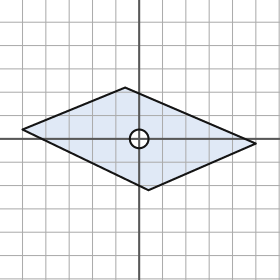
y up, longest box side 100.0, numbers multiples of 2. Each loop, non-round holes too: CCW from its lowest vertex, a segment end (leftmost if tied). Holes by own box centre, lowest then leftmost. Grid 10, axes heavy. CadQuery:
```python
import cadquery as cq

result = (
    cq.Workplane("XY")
    .moveTo(4.0, -22.0)
    .lineTo(50.0, -2.0)
    .lineTo(-6.0, 22.0)
    .lineTo(-50.0, 4.0)
    .close()
    .moveTo(0.0, 0.0)
    .circle(4.0)
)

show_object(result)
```